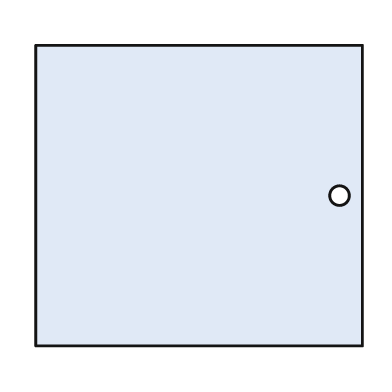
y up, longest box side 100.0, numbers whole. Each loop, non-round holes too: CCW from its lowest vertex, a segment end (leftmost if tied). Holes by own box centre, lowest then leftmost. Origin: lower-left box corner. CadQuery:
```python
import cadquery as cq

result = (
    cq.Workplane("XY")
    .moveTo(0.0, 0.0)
    .lineTo(100.0, 0.0)
    .lineTo(100.0, 92.0)
    .lineTo(0.0, 92.0)
    .close()
    .moveTo(93.0, 46.0)
    .circle(3.0)
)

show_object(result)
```